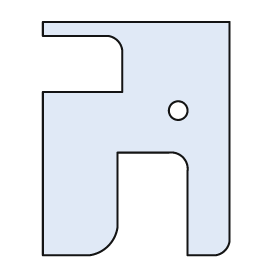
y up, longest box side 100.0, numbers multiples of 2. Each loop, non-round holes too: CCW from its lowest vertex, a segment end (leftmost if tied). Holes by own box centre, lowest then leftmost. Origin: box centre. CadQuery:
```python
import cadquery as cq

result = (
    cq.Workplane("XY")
    .moveTo(-40.0, -50.0)
    .lineTo(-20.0, -50.0)
    .threePointArc((-12.0, -46.0), (-8.0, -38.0))
    .lineTo(-8.0, -6.0)
    .lineTo(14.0, -6.0)
    .threePointArc((20.0, -8.0), (22.0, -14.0))
    .lineTo(22.0, -50.0)
    .lineTo(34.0, -50.0)
    .threePointArc((38.0, -48.0), (40.0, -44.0))
    .lineTo(40.0, 50.0)
    .lineTo(-40.0, 50.0)
    .lineTo(-40.0, 44.0)
    .lineTo(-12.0, 44.0)
    .threePointArc((-8.0, 42.0), (-6.0, 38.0))
    .lineTo(-6.0, 20.0)
    .lineTo(-40.0, 20.0)
    .close()
    .moveTo(18.0, 12.0)
    .circle(4.0)
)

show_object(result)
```